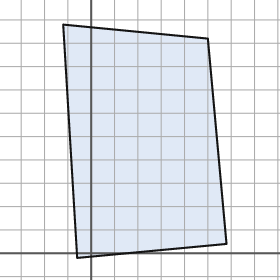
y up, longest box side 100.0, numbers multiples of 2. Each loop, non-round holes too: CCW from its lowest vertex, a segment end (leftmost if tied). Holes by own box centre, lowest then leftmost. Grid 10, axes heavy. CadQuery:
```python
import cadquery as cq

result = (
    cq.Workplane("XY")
    .moveTo(-6.0, -2.0)
    .lineTo(58.0, 4.0)
    .lineTo(50.0, 92.0)
    .lineTo(-12.0, 98.0)
    .close()
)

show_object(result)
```